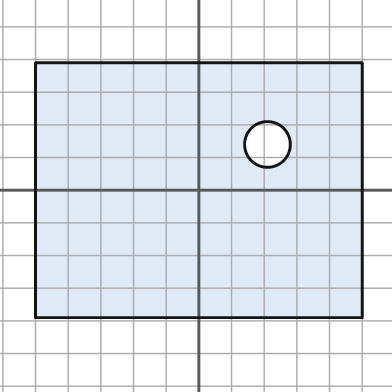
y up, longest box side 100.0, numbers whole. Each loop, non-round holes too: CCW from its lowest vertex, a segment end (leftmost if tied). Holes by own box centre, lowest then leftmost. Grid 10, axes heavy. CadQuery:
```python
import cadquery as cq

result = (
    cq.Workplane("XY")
    .moveTo(-50.0, -39.0)
    .lineTo(50.0, -39.0)
    .lineTo(50.0, 39.0)
    .lineTo(-50.0, 39.0)
    .close()
    .moveTo(21.0, 14.0)
    .circle(7.0)
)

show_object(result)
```